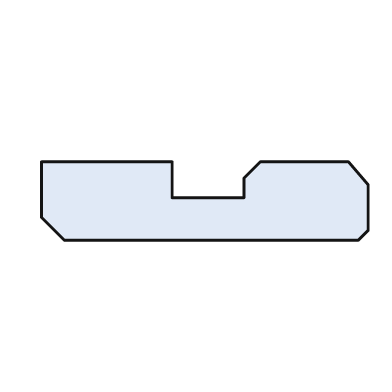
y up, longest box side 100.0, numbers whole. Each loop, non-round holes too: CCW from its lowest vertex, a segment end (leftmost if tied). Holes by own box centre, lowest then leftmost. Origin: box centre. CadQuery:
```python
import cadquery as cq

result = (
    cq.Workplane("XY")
    .moveTo(-43.0, -12.0)
    .lineTo(47.0, -12.0)
    .lineTo(50.0, -9.0)
    .lineTo(50.0, 5.0)
    .lineTo(44.0, 12.0)
    .lineTo(17.0, 12.0)
    .lineTo(12.0, 7.0)
    .lineTo(12.0, 1.0)
    .lineTo(-10.0, 1.0)
    .lineTo(-10.0, 12.0)
    .lineTo(-50.0, 12.0)
    .lineTo(-50.0, -5.0)
    .close()
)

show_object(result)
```